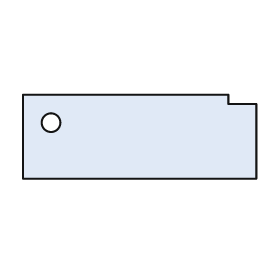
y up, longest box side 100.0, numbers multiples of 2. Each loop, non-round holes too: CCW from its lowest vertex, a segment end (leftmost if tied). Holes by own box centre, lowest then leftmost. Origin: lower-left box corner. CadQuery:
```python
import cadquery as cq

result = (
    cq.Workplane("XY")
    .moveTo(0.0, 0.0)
    .lineTo(100.0, 0.0)
    .lineTo(100.0, 32.0)
    .lineTo(88.0, 32.0)
    .lineTo(88.0, 36.0)
    .lineTo(0.0, 36.0)
    .close()
    .moveTo(12.0, 24.0)
    .circle(4.0)
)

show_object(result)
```